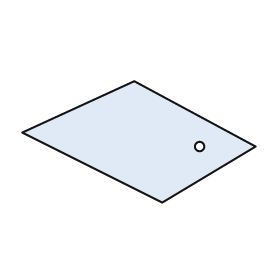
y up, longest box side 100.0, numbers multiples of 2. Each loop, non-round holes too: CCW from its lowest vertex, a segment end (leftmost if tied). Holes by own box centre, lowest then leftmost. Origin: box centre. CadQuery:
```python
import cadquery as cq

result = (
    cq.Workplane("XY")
    .moveTo(10.0, -26.0)
    .lineTo(50.0, -2.0)
    .lineTo(-2.0, 26.0)
    .lineTo(-50.0, 4.0)
    .close()
    .moveTo(26.0, -2.0)
    .circle(2.0)
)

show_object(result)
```